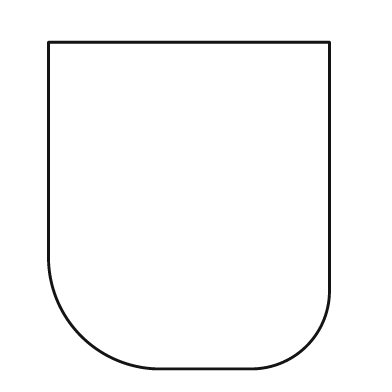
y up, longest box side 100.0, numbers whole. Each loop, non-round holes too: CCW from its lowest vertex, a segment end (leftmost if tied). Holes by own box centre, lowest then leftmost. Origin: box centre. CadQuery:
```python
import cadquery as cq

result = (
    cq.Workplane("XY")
    .moveTo(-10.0, -50.0)
    .lineTo(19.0, -50.0)
    .threePointArc((36.0, -43.0), (43.0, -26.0))
    .lineTo(43.0, 50.0)
    .lineTo(-43.0, 50.0)
    .lineTo(-43.0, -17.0)
    .threePointArc((-33.0, -40.0), (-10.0, -50.0))
    .close()
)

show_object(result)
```